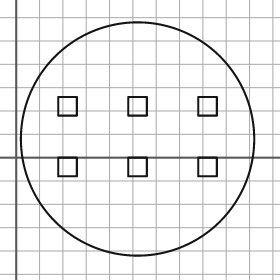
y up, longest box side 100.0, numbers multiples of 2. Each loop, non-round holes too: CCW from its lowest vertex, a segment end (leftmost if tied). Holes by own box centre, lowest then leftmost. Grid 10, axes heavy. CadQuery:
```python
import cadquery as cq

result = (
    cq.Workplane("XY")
    .moveTo(52.0, 8.0)
    .circle(50.0)
    .moveTo(18.0, -8.0)
    .lineTo(26.0, -8.0)
    .lineTo(26.0, 0.0)
    .lineTo(18.0, 0.0)
    .close()
    .moveTo(48.0, -8.0)
    .lineTo(56.0, -8.0)
    .lineTo(56.0, 0.0)
    .lineTo(48.0, 0.0)
    .close()
    .moveTo(78.0, -8.0)
    .lineTo(86.0, -8.0)
    .lineTo(86.0, 0.0)
    .lineTo(78.0, 0.0)
    .close()
    .moveTo(18.0, 18.0)
    .lineTo(26.0, 18.0)
    .lineTo(26.0, 26.0)
    .lineTo(18.0, 26.0)
    .close()
    .moveTo(48.0, 18.0)
    .lineTo(56.0, 18.0)
    .lineTo(56.0, 26.0)
    .lineTo(48.0, 26.0)
    .close()
    .moveTo(78.0, 18.0)
    .lineTo(86.0, 18.0)
    .lineTo(86.0, 26.0)
    .lineTo(78.0, 26.0)
    .close()
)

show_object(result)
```